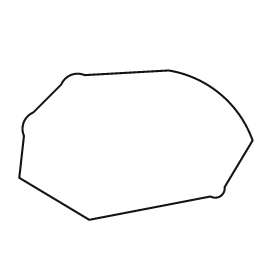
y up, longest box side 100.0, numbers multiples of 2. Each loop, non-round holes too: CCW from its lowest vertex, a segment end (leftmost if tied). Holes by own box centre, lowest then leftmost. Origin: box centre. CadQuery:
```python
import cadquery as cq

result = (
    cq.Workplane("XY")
    .moveTo(-20.0, -32.0)
    .lineTo(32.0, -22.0)
    .threePointArc((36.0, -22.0), (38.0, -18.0))
    .lineTo(50.0, 2.0)
    .threePointArc((36.0, 22.0), (14.0, 32.0))
    .lineTo(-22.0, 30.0)
    .threePointArc((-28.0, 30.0), (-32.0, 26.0))
    .lineTo(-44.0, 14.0)
    .threePointArc((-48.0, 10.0), (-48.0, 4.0))
    .lineTo(-50.0, -14.0)
    .close()
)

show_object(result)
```